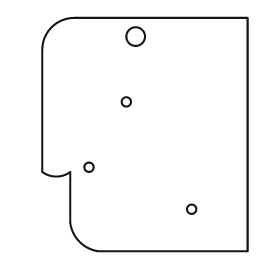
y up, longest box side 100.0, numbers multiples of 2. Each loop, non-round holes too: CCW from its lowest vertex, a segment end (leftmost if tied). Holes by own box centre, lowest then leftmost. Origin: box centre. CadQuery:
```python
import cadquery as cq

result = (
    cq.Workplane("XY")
    .moveTo(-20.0, -50.0)
    .lineTo(44.0, -50.0)
    .lineTo(44.0, 50.0)
    .lineTo(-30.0, 50.0)
    .threePointArc((-40.0, 46.0), (-44.0, 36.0))
    .lineTo(-44.0, -16.0)
    .threePointArc((-38.0, -18.0), (-32.0, -16.0))
    .lineTo(-32.0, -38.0)
    .threePointArc((-28.0, -46.0), (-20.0, -50.0))
    .close()
    .moveTo(20.0, -32.0)
    .circle(2.0)
    .moveTo(-24.0, -14.0)
    .circle(2.0)
    .moveTo(-8.0, 14.0)
    .circle(2.0)
    .moveTo(-4.0, 42.0)
    .circle(4.0)
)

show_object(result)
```